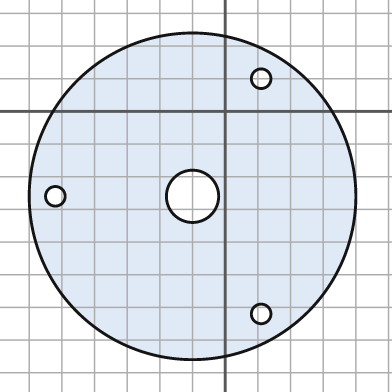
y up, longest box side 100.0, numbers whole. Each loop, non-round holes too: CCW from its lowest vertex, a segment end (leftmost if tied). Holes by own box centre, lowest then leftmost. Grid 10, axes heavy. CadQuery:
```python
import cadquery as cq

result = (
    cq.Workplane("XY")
    .moveTo(-10.0, -26.0)
    .circle(50.0)
    .moveTo(11.0, -62.0)
    .circle(3.0)
    .moveTo(-52.0, -26.0)
    .circle(3.0)
    .moveTo(-10.0, -26.0)
    .circle(8.0)
    .moveTo(11.0, 10.0)
    .circle(3.0)
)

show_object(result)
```